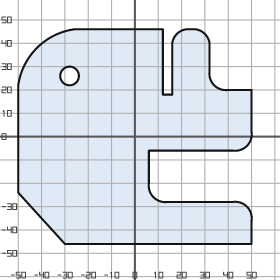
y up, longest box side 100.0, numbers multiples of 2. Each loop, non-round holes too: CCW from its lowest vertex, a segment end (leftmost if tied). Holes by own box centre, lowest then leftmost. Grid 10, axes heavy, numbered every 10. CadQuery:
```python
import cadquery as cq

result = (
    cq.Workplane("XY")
    .moveTo(-30.0, -46.0)
    .lineTo(50.0, -46.0)
    .lineTo(50.0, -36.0)
    .threePointArc((48.0, -30.0), (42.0, -28.0))
    .lineTo(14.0, -28.0)
    .threePointArc((8.0, -26.0), (6.0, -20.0))
    .lineTo(6.0, -6.0)
    .lineTo(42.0, -6.0)
    .threePointArc((48.0, -4.0), (50.0, 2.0))
    .lineTo(50.0, 20.0)
    .lineTo(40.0, 20.0)
    .threePointArc((34.0, 22.0), (32.0, 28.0))
    .lineTo(32.0, 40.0)
    .threePointArc((30.0, 44.0), (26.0, 46.0))
    .lineTo(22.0, 46.0)
    .threePointArc((18.0, 44.0), (16.0, 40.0))
    .lineTo(16.0, 18.0)
    .lineTo(12.0, 18.0)
    .lineTo(12.0, 46.0)
    .lineTo(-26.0, 46.0)
    .threePointArc((-42.0, 38.0), (-50.0, 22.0))
    .lineTo(-50.0, -24.0)
    .close()
    .moveTo(-28.0, 26.0)
    .circle(4.0)
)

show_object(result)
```